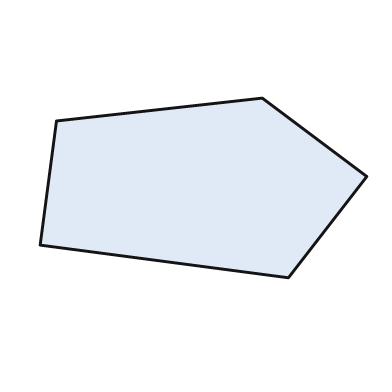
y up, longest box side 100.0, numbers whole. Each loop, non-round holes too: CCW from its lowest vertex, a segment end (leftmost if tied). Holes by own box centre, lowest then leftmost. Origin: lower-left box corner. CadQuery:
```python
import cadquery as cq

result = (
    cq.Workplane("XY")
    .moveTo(76.0, 0.0)
    .lineTo(100.0, 31.0)
    .lineTo(68.0, 55.0)
    .lineTo(5.0, 48.0)
    .lineTo(0.0, 10.0)
    .close()
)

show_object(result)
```